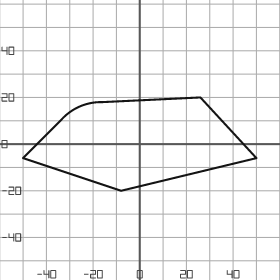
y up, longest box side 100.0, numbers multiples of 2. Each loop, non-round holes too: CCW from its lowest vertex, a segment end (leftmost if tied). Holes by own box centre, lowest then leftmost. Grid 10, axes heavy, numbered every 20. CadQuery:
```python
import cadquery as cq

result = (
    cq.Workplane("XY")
    .moveTo(-8.0, -20.0)
    .lineTo(50.0, -6.0)
    .lineTo(26.0, 20.0)
    .lineTo(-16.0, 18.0)
    .threePointArc((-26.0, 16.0), (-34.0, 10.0))
    .lineTo(-50.0, -6.0)
    .close()
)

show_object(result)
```